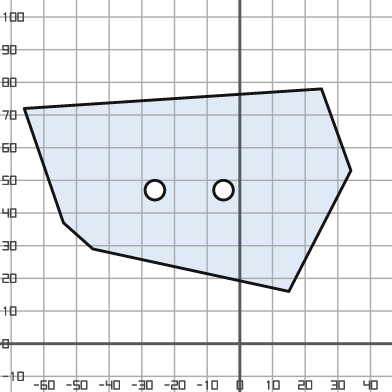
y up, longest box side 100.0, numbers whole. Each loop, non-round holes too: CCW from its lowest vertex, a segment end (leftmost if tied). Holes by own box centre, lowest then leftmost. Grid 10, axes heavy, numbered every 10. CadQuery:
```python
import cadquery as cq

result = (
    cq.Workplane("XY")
    .moveTo(15.0, 16.0)
    .lineTo(34.0, 53.0)
    .lineTo(25.0, 78.0)
    .lineTo(-66.0, 72.0)
    .lineTo(-54.0, 37.0)
    .lineTo(-45.0, 29.0)
    .close()
    .moveTo(-26.0, 47.0)
    .circle(3.0)
    .moveTo(-5.0, 47.0)
    .circle(3.0)
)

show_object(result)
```